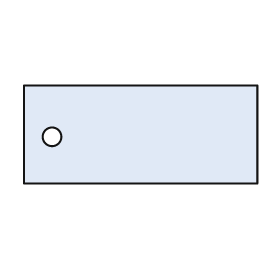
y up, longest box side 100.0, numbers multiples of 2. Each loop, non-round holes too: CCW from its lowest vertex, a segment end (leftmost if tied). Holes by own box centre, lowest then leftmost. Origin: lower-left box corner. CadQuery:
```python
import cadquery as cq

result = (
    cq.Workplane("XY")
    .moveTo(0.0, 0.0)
    .lineTo(100.0, 0.0)
    .lineTo(100.0, 42.0)
    .lineTo(0.0, 42.0)
    .close()
    .moveTo(12.0, 20.0)
    .circle(4.0)
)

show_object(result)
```